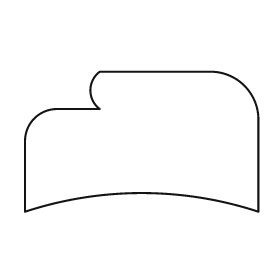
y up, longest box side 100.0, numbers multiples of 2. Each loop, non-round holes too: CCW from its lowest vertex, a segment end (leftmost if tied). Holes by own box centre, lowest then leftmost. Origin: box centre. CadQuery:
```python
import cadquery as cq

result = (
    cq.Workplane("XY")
    .moveTo(-50.0, -30.0)
    .threePointArc((0.0, -22.0), (50.0, -30.0))
    .lineTo(50.0, 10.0)
    .threePointArc((44.0, 24.0), (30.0, 30.0))
    .lineTo(-18.0, 30.0)
    .threePointArc((-22.0, 22.0), (-18.0, 14.0))
    .lineTo(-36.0, 14.0)
    .threePointArc((-46.0, 10.0), (-50.0, 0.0))
    .close()
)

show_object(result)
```